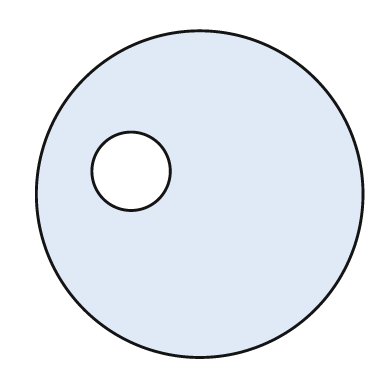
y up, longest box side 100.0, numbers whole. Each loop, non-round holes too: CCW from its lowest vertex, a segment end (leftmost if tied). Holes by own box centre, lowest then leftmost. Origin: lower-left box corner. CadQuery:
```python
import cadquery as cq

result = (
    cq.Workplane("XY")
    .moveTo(50.0, 50.0)
    .circle(50.0)
    .moveTo(29.0, 57.0)
    .circle(12.0)
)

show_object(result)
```